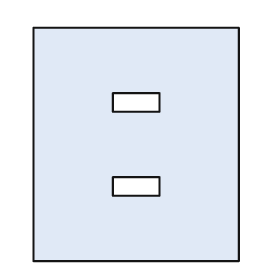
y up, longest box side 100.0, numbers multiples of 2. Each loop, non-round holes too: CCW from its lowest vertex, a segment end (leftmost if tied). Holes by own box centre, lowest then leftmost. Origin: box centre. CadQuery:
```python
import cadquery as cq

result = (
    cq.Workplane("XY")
    .moveTo(-44.0, -50.0)
    .lineTo(44.0, -50.0)
    .lineTo(44.0, 50.0)
    .lineTo(-44.0, 50.0)
    .close()
    .moveTo(-10.0, -22.0)
    .lineTo(10.0, -22.0)
    .lineTo(10.0, -14.0)
    .lineTo(-10.0, -14.0)
    .close()
    .moveTo(-10.0, 14.0)
    .lineTo(10.0, 14.0)
    .lineTo(10.0, 22.0)
    .lineTo(-10.0, 22.0)
    .close()
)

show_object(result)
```